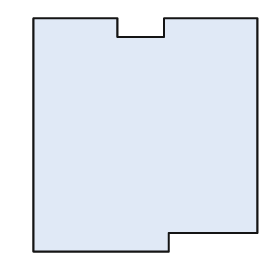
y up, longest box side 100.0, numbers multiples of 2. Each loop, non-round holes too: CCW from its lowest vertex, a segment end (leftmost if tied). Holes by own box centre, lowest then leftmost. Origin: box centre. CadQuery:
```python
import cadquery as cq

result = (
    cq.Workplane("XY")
    .moveTo(-48.0, -50.0)
    .lineTo(10.0, -50.0)
    .lineTo(10.0, -42.0)
    .lineTo(48.0, -42.0)
    .lineTo(48.0, 50.0)
    .lineTo(8.0, 50.0)
    .lineTo(8.0, 42.0)
    .lineTo(-12.0, 42.0)
    .lineTo(-12.0, 50.0)
    .lineTo(-48.0, 50.0)
    .close()
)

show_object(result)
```